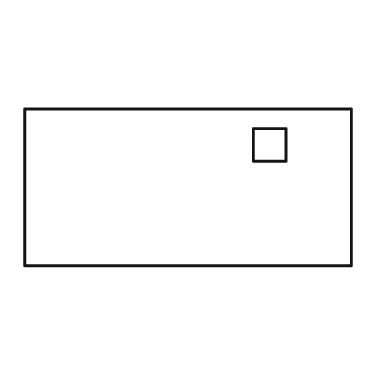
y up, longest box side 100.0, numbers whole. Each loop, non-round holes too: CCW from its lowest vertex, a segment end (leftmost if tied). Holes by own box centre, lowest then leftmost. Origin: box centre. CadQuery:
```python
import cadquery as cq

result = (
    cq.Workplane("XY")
    .moveTo(-50.0, -24.0)
    .lineTo(50.0, -24.0)
    .lineTo(50.0, 24.0)
    .lineTo(-50.0, 24.0)
    .close()
    .moveTo(20.0, 8.0)
    .lineTo(30.0, 8.0)
    .lineTo(30.0, 18.0)
    .lineTo(20.0, 18.0)
    .close()
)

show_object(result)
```